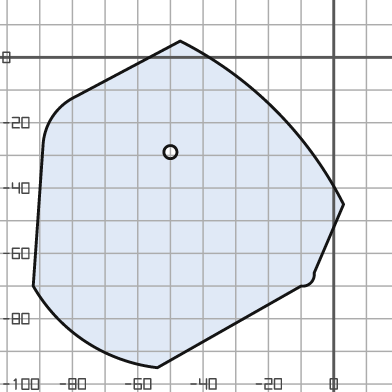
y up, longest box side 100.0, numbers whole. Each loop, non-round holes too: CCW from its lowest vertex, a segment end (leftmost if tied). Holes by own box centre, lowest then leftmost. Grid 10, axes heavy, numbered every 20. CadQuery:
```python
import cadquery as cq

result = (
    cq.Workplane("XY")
    .moveTo(-54.0, -95.0)
    .lineTo(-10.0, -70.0)
    .threePointArc((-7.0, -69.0), (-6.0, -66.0))
    .lineTo(3.0, -45.0)
    .threePointArc((-18.0, -16.0), (-47.0, 5.0))
    .lineTo(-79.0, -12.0)
    .threePointArc((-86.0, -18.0), (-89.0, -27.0))
    .lineTo(-92.0, -70.0)
    .threePointArc((-76.0, -87.0), (-54.0, -95.0))
    .close()
    .moveTo(-50.0, -29.0)
    .circle(2.0)
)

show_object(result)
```